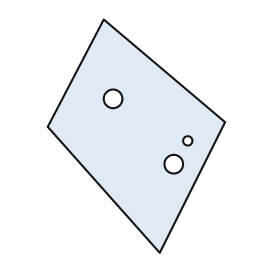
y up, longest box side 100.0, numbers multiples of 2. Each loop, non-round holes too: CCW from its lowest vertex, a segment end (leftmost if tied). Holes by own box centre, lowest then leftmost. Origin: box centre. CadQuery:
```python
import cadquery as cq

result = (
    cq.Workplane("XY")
    .moveTo(10.0, -50.0)
    .lineTo(38.0, 6.0)
    .lineTo(-14.0, 50.0)
    .lineTo(-38.0, 4.0)
    .close()
    .moveTo(16.0, -12.0)
    .circle(4.0)
    .moveTo(22.0, -2.0)
    .circle(2.0)
    .moveTo(-10.0, 16.0)
    .circle(4.0)
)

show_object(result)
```